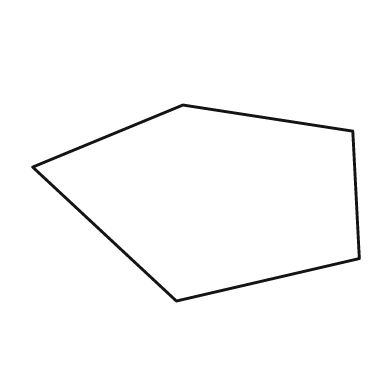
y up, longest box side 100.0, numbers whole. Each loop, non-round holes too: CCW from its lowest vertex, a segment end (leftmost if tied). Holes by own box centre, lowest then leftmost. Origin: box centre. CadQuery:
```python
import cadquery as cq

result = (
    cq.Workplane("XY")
    .moveTo(-6.0, -30.0)
    .lineTo(50.0, -17.0)
    .lineTo(48.0, 22.0)
    .lineTo(-4.0, 30.0)
    .lineTo(-50.0, 11.0)
    .close()
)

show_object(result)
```